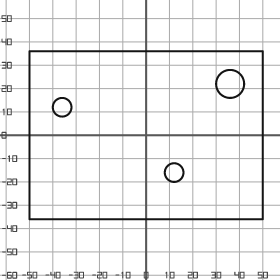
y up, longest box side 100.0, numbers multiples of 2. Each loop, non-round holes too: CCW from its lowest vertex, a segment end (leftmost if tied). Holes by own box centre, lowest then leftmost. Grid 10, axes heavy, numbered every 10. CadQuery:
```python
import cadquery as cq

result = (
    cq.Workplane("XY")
    .moveTo(-50.0, -36.0)
    .lineTo(50.0, -36.0)
    .lineTo(50.0, 36.0)
    .lineTo(-50.0, 36.0)
    .close()
    .moveTo(12.0, -16.0)
    .circle(4.0)
    .moveTo(-36.0, 12.0)
    .circle(4.0)
    .moveTo(36.0, 22.0)
    .circle(6.0)
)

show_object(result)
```